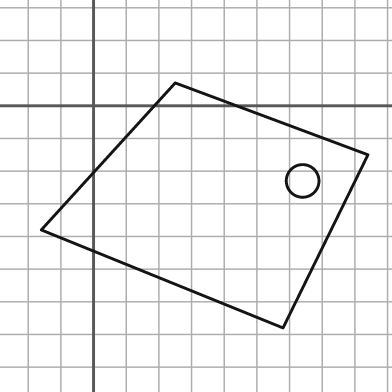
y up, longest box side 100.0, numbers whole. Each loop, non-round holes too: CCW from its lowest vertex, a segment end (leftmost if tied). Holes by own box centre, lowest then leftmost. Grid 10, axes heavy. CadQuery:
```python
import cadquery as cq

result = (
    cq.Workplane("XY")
    .moveTo(58.0, -68.0)
    .lineTo(84.0, -15.0)
    .lineTo(25.0, 7.0)
    .lineTo(-16.0, -38.0)
    .close()
    .moveTo(64.0, -23.0)
    .circle(5.0)
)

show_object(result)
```